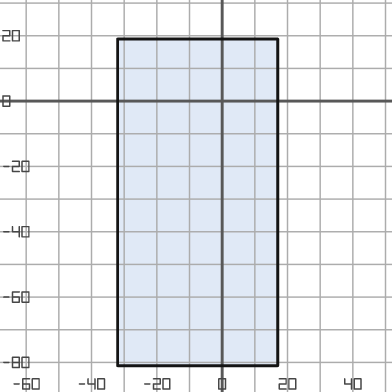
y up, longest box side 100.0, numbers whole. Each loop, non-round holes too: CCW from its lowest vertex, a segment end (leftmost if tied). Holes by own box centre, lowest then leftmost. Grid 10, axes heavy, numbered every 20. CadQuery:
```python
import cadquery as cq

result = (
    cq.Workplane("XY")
    .moveTo(-32.0, -81.0)
    .lineTo(17.0, -81.0)
    .lineTo(17.0, 19.0)
    .lineTo(-32.0, 19.0)
    .close()
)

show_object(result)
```